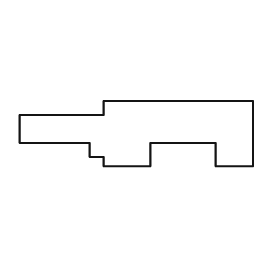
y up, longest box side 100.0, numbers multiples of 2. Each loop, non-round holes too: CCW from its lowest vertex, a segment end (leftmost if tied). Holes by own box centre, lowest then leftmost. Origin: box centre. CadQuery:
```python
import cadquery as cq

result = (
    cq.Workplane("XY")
    .moveTo(-14.0, -14.0)
    .lineTo(6.0, -14.0)
    .lineTo(6.0, -4.0)
    .lineTo(34.0, -4.0)
    .lineTo(34.0, -14.0)
    .lineTo(50.0, -14.0)
    .lineTo(50.0, 14.0)
    .lineTo(-14.0, 14.0)
    .lineTo(-14.0, 8.0)
    .lineTo(-50.0, 8.0)
    .lineTo(-50.0, -4.0)
    .lineTo(-20.0, -4.0)
    .lineTo(-20.0, -10.0)
    .lineTo(-14.0, -10.0)
    .close()
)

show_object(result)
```